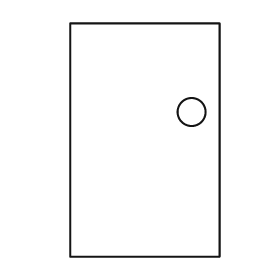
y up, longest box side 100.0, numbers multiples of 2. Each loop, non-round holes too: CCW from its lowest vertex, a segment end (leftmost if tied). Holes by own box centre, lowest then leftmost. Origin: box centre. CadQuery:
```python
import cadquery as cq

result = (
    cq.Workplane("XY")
    .moveTo(-32.0, -50.0)
    .lineTo(32.0, -50.0)
    .lineTo(32.0, 50.0)
    .lineTo(-32.0, 50.0)
    .close()
    .moveTo(20.0, 12.0)
    .circle(6.0)
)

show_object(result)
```